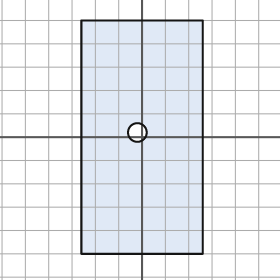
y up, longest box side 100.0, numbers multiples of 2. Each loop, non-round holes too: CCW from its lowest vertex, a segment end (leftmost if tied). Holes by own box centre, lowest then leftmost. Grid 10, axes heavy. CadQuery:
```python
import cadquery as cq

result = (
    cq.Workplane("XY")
    .moveTo(-26.0, -50.0)
    .lineTo(26.0, -50.0)
    .lineTo(26.0, 50.0)
    .lineTo(-26.0, 50.0)
    .close()
    .moveTo(-2.0, 2.0)
    .circle(4.0)
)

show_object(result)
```